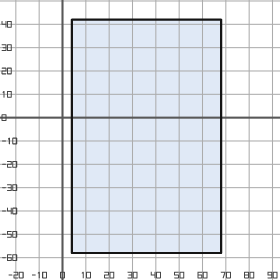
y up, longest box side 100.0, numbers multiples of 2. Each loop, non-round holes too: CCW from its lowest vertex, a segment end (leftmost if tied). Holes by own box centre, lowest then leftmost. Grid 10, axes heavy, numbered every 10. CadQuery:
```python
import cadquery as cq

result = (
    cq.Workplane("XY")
    .moveTo(4.0, -58.0)
    .lineTo(68.0, -58.0)
    .lineTo(68.0, 42.0)
    .lineTo(4.0, 42.0)
    .close()
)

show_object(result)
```